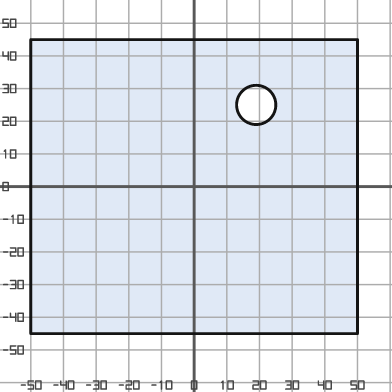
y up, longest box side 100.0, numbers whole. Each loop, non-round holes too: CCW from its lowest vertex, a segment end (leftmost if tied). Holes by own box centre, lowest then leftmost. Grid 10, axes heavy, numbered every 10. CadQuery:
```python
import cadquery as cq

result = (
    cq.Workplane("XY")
    .moveTo(-50.0, -45.0)
    .lineTo(50.0, -45.0)
    .lineTo(50.0, 45.0)
    .lineTo(-50.0, 45.0)
    .close()
    .moveTo(19.0, 25.0)
    .circle(6.0)
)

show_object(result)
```